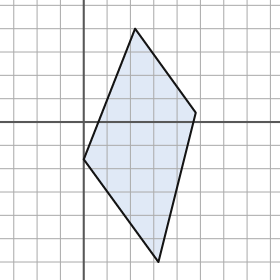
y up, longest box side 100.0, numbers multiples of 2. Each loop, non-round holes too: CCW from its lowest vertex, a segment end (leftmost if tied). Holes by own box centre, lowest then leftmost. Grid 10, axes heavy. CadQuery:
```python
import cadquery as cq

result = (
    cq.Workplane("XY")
    .moveTo(32.0, -60.0)
    .lineTo(48.0, 4.0)
    .lineTo(22.0, 40.0)
    .lineTo(0.0, -16.0)
    .close()
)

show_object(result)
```